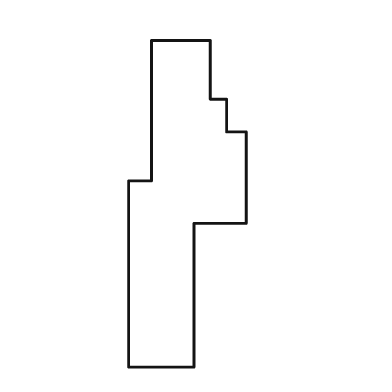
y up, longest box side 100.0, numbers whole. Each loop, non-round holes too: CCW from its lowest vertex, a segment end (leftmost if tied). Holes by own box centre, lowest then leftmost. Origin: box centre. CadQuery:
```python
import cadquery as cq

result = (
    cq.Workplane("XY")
    .moveTo(-18.0, -50.0)
    .lineTo(2.0, -50.0)
    .lineTo(2.0, -6.0)
    .lineTo(18.0, -6.0)
    .lineTo(18.0, 22.0)
    .lineTo(12.0, 22.0)
    .lineTo(12.0, 32.0)
    .lineTo(7.0, 32.0)
    .lineTo(7.0, 50.0)
    .lineTo(-11.0, 50.0)
    .lineTo(-11.0, 7.0)
    .lineTo(-18.0, 7.0)
    .close()
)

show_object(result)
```